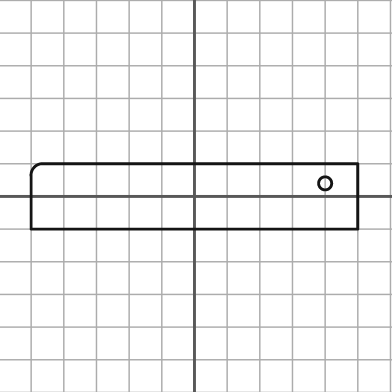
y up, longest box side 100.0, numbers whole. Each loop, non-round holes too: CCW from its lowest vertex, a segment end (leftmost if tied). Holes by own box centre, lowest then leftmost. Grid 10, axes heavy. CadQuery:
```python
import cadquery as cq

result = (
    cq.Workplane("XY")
    .moveTo(-50.0, -10.0)
    .lineTo(50.0, -10.0)
    .lineTo(50.0, 10.0)
    .lineTo(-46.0, 10.0)
    .threePointArc((-49.0, 9.0), (-50.0, 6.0))
    .close()
    .moveTo(40.0, 4.0)
    .circle(2.0)
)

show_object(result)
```